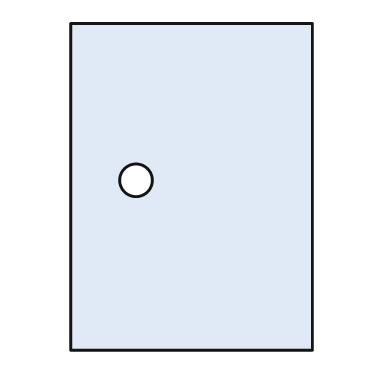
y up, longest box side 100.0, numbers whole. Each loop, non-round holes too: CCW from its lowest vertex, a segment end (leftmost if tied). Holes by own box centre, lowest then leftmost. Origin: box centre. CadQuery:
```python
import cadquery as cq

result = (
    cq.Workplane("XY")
    .moveTo(-37.0, -50.0)
    .lineTo(37.0, -50.0)
    .lineTo(37.0, 50.0)
    .lineTo(-37.0, 50.0)
    .close()
    .moveTo(-17.0, 2.0)
    .circle(5.0)
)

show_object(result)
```